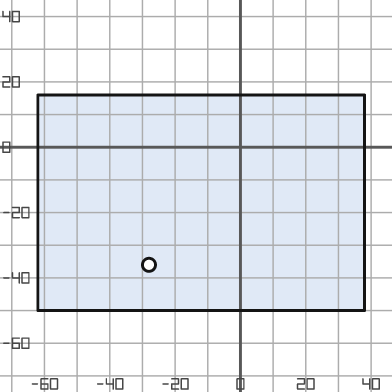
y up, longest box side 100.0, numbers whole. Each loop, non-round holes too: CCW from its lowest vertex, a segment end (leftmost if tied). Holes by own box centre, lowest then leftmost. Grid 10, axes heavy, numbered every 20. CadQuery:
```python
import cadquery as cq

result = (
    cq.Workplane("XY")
    .moveTo(-62.0, -50.0)
    .lineTo(38.0, -50.0)
    .lineTo(38.0, 16.0)
    .lineTo(-62.0, 16.0)
    .close()
    .moveTo(-28.0, -36.0)
    .circle(2.0)
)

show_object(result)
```